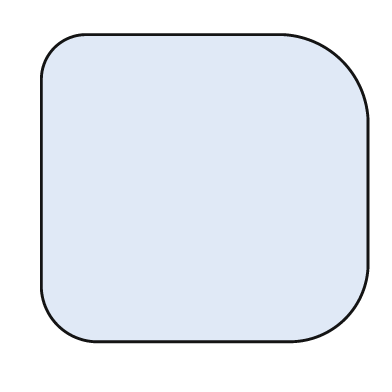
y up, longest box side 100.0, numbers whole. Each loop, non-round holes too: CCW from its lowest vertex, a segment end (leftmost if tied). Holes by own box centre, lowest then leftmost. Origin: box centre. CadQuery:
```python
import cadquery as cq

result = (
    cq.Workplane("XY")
    .moveTo(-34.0, -47.0)
    .lineTo(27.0, -47.0)
    .threePointArc((43.0, -40.0), (50.0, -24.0))
    .lineTo(50.0, 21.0)
    .threePointArc((42.0, 39.0), (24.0, 47.0))
    .lineTo(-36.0, 47.0)
    .threePointArc((-46.0, 43.0), (-50.0, 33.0))
    .lineTo(-50.0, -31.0)
    .threePointArc((-45.0, -42.0), (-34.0, -47.0))
    .close()
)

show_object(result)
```